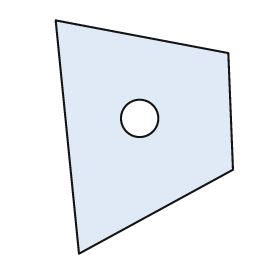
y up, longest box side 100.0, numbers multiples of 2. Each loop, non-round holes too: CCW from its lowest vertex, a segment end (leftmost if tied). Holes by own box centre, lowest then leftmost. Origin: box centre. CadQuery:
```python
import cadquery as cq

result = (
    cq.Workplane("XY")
    .moveTo(-28.0, -50.0)
    .lineTo(38.0, -14.0)
    .lineTo(36.0, 36.0)
    .lineTo(-38.0, 50.0)
    .close()
    .moveTo(-2.0, 8.0)
    .circle(8.0)
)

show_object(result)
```